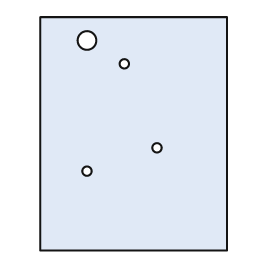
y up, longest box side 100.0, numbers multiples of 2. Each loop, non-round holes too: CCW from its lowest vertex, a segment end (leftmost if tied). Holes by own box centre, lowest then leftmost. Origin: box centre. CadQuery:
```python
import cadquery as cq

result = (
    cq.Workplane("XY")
    .moveTo(-40.0, -50.0)
    .lineTo(40.0, -50.0)
    .lineTo(40.0, 50.0)
    .lineTo(-40.0, 50.0)
    .close()
    .moveTo(-20.0, -16.0)
    .circle(2.0)
    .moveTo(10.0, -6.0)
    .circle(2.0)
    .moveTo(-4.0, 30.0)
    .circle(2.0)
    .moveTo(-20.0, 40.0)
    .circle(4.0)
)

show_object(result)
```